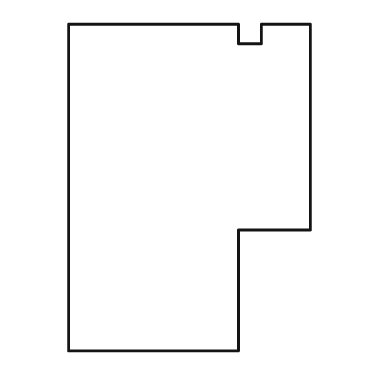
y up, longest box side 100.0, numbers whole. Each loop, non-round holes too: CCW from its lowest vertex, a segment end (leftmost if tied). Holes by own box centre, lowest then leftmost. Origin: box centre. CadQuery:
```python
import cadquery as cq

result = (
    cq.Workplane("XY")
    .moveTo(-37.0, -50.0)
    .lineTo(15.0, -50.0)
    .lineTo(15.0, -13.0)
    .lineTo(37.0, -13.0)
    .lineTo(37.0, 50.0)
    .lineTo(22.0, 50.0)
    .lineTo(22.0, 44.0)
    .lineTo(15.0, 44.0)
    .lineTo(15.0, 50.0)
    .lineTo(-37.0, 50.0)
    .close()
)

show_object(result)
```